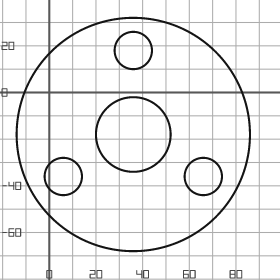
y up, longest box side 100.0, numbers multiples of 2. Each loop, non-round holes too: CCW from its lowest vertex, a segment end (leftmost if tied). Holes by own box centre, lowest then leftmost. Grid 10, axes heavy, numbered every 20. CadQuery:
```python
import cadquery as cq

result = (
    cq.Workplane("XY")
    .moveTo(36.0, -18.0)
    .circle(50.0)
    .moveTo(6.0, -36.0)
    .circle(8.0)
    .moveTo(66.0, -36.0)
    .circle(8.0)
    .moveTo(36.0, -18.0)
    .circle(16.0)
    .moveTo(36.0, 18.0)
    .circle(8.0)
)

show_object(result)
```